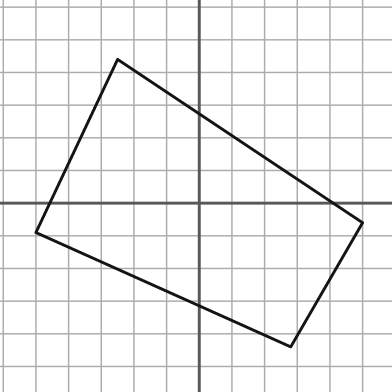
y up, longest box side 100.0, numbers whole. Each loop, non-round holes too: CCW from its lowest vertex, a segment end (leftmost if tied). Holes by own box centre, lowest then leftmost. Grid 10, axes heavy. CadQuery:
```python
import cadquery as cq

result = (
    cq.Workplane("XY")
    .moveTo(28.0, -44.0)
    .lineTo(50.0, -6.0)
    .lineTo(-25.0, 44.0)
    .lineTo(-50.0, -9.0)
    .close()
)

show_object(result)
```